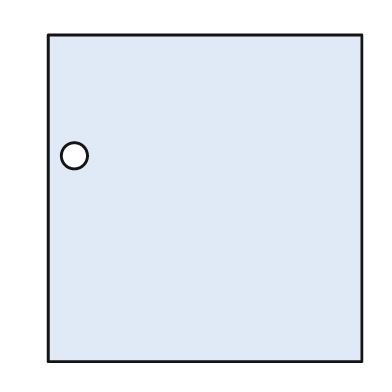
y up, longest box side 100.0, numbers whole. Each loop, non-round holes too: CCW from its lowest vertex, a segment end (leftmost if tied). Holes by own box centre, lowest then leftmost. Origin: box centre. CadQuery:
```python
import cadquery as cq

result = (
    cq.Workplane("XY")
    .moveTo(-48.0, -50.0)
    .lineTo(48.0, -50.0)
    .lineTo(48.0, 50.0)
    .lineTo(-48.0, 50.0)
    .close()
    .moveTo(-40.0, 13.0)
    .circle(4.0)
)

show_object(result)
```